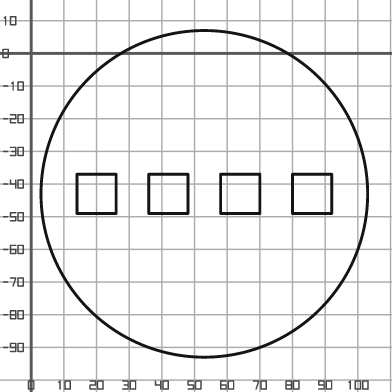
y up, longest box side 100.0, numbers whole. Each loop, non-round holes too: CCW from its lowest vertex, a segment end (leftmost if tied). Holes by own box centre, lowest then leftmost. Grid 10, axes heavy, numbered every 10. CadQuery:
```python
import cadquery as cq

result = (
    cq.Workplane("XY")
    .moveTo(53.0, -43.0)
    .circle(50.0)
    .moveTo(14.0, -49.0)
    .lineTo(26.0, -49.0)
    .lineTo(26.0, -37.0)
    .lineTo(14.0, -37.0)
    .close()
    .moveTo(36.0, -49.0)
    .lineTo(48.0, -49.0)
    .lineTo(48.0, -37.0)
    .lineTo(36.0, -37.0)
    .close()
    .moveTo(58.0, -49.0)
    .lineTo(70.0, -49.0)
    .lineTo(70.0, -37.0)
    .lineTo(58.0, -37.0)
    .close()
    .moveTo(80.0, -49.0)
    .lineTo(92.0, -49.0)
    .lineTo(92.0, -37.0)
    .lineTo(80.0, -37.0)
    .close()
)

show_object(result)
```